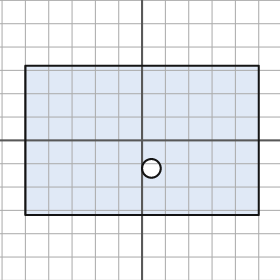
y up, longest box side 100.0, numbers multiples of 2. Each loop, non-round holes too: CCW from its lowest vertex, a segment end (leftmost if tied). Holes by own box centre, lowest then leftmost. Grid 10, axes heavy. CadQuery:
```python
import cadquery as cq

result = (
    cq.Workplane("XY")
    .moveTo(-50.0, -32.0)
    .lineTo(50.0, -32.0)
    .lineTo(50.0, 32.0)
    .lineTo(-50.0, 32.0)
    .close()
    .moveTo(4.0, -12.0)
    .circle(4.0)
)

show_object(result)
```